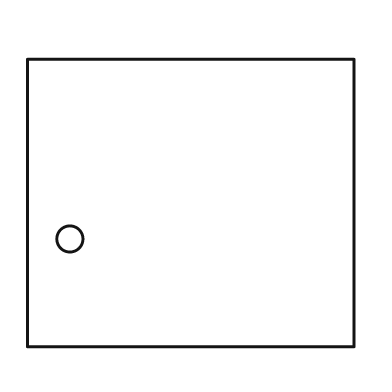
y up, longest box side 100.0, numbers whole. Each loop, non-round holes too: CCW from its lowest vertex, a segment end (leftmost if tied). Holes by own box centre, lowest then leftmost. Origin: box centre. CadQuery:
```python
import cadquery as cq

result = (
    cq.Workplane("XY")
    .moveTo(-50.0, -44.0)
    .lineTo(50.0, -44.0)
    .lineTo(50.0, 44.0)
    .lineTo(-50.0, 44.0)
    .close()
    .moveTo(-37.0, -11.0)
    .circle(4.0)
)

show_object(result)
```